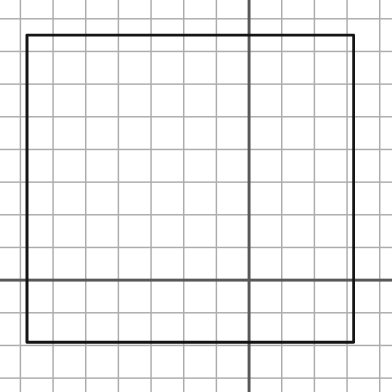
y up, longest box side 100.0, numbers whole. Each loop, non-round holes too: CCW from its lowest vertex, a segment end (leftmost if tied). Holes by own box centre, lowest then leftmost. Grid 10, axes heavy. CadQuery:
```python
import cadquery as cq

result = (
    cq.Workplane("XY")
    .moveTo(-68.0, -19.0)
    .lineTo(32.0, -19.0)
    .lineTo(32.0, 75.0)
    .lineTo(-68.0, 75.0)
    .close()
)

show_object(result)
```